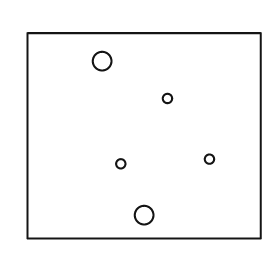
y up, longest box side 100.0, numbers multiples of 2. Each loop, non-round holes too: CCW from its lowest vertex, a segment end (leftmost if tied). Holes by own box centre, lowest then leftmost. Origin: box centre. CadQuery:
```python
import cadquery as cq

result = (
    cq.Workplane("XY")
    .moveTo(-50.0, -44.0)
    .lineTo(50.0, -44.0)
    .lineTo(50.0, 44.0)
    .lineTo(-50.0, 44.0)
    .close()
    .moveTo(0.0, -34.0)
    .circle(4.0)
    .moveTo(-10.0, -12.0)
    .circle(2.0)
    .moveTo(28.0, -10.0)
    .circle(2.0)
    .moveTo(10.0, 16.0)
    .circle(2.0)
    .moveTo(-18.0, 32.0)
    .circle(4.0)
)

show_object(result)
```